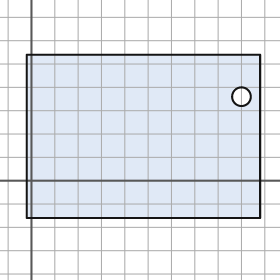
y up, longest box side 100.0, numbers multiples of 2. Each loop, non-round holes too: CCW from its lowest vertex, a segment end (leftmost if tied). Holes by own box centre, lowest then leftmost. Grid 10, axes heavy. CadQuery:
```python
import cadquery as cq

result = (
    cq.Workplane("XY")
    .moveTo(-2.0, -16.0)
    .lineTo(98.0, -16.0)
    .lineTo(98.0, 54.0)
    .lineTo(-2.0, 54.0)
    .close()
    .moveTo(90.0, 36.0)
    .circle(4.0)
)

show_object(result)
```